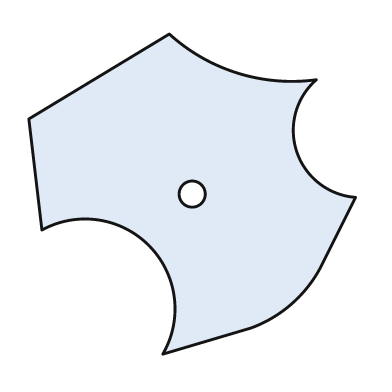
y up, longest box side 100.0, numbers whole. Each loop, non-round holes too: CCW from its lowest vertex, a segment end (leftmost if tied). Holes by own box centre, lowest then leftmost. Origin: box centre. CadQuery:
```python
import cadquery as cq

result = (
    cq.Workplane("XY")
    .moveTo(-9.0, -49.0)
    .lineTo(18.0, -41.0)
    .threePointArc((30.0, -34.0), (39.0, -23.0))
    .lineTo(50.0, -1.0)
    .threePointArc((32.0, 13.0), (38.0, 35.0))
    .threePointArc((14.0, 37.0), (-7.0, 49.0))
    .lineTo(-50.0, 23.0)
    .lineTo(-46.0, -11.0)
    .threePointArc((-13.0, -16.0), (-9.0, -49.0))
    .close()
    .moveTo(0.0, 0.0)
    .circle(4.0)
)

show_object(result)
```